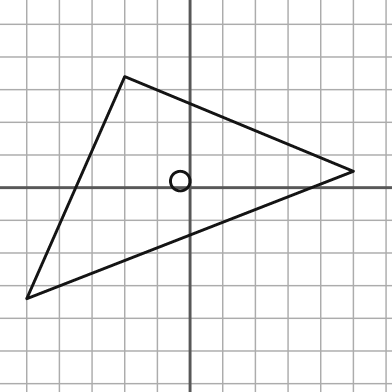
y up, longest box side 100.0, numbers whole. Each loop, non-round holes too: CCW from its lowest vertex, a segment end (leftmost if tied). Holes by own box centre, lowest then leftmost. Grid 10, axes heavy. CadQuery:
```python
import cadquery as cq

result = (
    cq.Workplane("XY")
    .moveTo(-50.0, -34.0)
    .lineTo(50.0, 5.0)
    .lineTo(-20.0, 34.0)
    .close()
    .moveTo(-3.0, 2.0)
    .circle(3.0)
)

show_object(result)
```